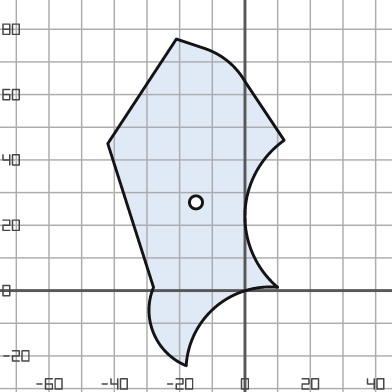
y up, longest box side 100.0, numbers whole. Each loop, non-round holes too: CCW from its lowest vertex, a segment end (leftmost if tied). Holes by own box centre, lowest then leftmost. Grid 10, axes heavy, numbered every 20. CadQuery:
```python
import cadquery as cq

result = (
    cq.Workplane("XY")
    .moveTo(-18.0, -23.0)
    .threePointArc((-9.0, -5.0), (10.0, 1.0))
    .threePointArc((0.0, 24.0), (12.0, 46.0))
    .lineTo(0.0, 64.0)
    .threePointArc((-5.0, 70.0), (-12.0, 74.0))
    .lineTo(-21.0, 77.0)
    .lineTo(-42.0, 45.0)
    .lineTo(-28.0, 1.0)
    .threePointArc((-28.0, -13.0), (-18.0, -23.0))
    .close()
    .moveTo(-15.0, 27.0)
    .circle(2.0)
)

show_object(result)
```